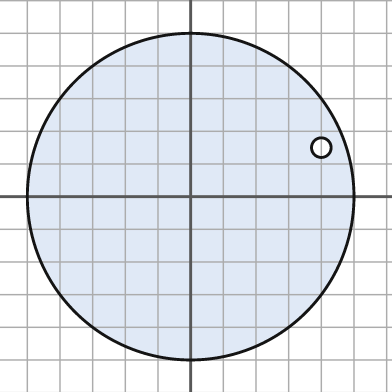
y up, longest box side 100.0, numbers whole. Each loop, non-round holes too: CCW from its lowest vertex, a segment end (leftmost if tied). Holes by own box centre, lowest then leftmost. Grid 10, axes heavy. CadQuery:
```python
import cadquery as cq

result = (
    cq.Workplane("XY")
    .moveTo(0.0, 0.0)
    .circle(50.0)
    .moveTo(40.0, 15.0)
    .circle(3.0)
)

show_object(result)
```